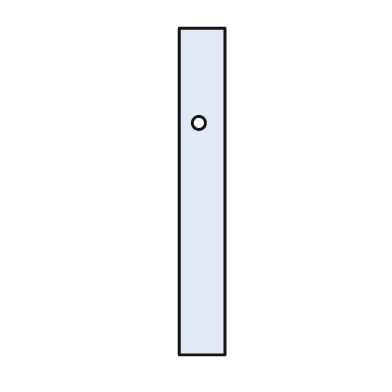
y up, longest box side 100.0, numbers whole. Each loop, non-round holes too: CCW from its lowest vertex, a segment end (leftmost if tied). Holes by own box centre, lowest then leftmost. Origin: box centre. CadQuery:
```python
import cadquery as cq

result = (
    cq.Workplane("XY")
    .moveTo(-7.0, -50.0)
    .lineTo(7.0, -50.0)
    .lineTo(7.0, 50.0)
    .lineTo(-7.0, 50.0)
    .close()
    .moveTo(-1.0, 21.0)
    .circle(2.0)
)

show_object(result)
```